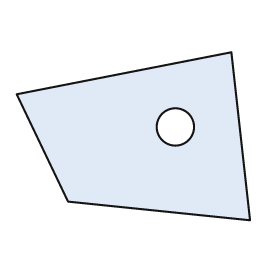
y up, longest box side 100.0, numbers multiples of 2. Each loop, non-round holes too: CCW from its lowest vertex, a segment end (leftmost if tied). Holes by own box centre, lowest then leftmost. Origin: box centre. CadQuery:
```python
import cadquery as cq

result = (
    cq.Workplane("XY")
    .moveTo(50.0, -36.0)
    .lineTo(42.0, 36.0)
    .lineTo(-50.0, 18.0)
    .lineTo(-28.0, -28.0)
    .close()
    .moveTo(18.0, 4.0)
    .circle(8.0)
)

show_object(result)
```